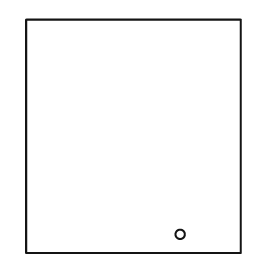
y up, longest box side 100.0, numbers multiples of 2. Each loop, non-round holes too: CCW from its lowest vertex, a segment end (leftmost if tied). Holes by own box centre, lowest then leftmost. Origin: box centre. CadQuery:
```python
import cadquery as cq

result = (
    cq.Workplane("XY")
    .moveTo(-46.0, -50.0)
    .lineTo(46.0, -50.0)
    .lineTo(46.0, 50.0)
    .lineTo(-46.0, 50.0)
    .close()
    .moveTo(20.0, -42.0)
    .circle(2.0)
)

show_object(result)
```